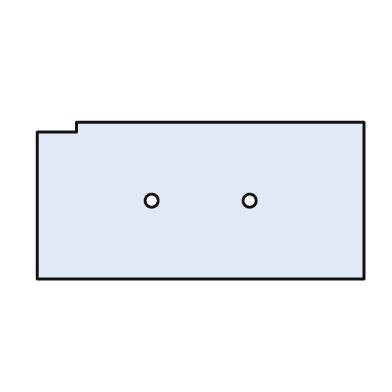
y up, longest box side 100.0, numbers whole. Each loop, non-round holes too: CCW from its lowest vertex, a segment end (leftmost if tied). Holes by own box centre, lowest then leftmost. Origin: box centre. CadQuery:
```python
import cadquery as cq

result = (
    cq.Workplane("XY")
    .moveTo(-50.0, -24.0)
    .lineTo(50.0, -24.0)
    .lineTo(50.0, 24.0)
    .lineTo(-38.0, 24.0)
    .lineTo(-38.0, 21.0)
    .lineTo(-50.0, 21.0)
    .close()
    .moveTo(-15.0, 0.0)
    .circle(2.0)
    .moveTo(15.0, 0.0)
    .circle(2.0)
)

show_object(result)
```